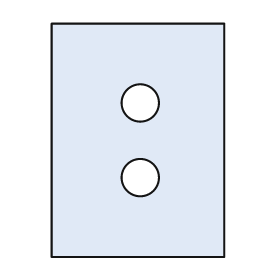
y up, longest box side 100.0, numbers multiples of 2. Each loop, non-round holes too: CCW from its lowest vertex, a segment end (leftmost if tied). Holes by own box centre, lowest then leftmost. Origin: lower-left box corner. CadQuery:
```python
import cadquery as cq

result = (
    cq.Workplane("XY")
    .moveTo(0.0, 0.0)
    .lineTo(74.0, 0.0)
    .lineTo(74.0, 100.0)
    .lineTo(0.0, 100.0)
    .close()
    .moveTo(38.0, 34.0)
    .circle(8.0)
    .moveTo(38.0, 66.0)
    .circle(8.0)
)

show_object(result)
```